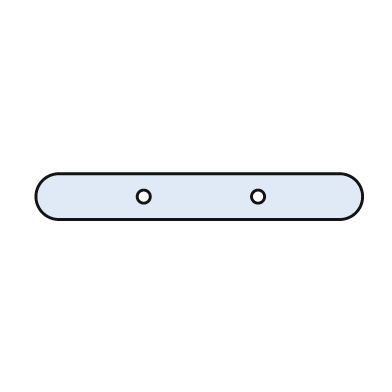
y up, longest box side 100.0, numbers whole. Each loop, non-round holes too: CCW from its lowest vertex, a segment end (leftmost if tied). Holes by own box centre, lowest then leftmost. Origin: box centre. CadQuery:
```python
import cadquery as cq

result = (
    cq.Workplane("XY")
    .moveTo(-43.0, -7.0)
    .lineTo(43.0, -7.0)
    .threePointArc((50.0, 0.0), (43.0, 7.0))
    .lineTo(-43.0, 7.0)
    .threePointArc((-50.0, 0.0), (-43.0, -7.0))
    .close()
    .moveTo(-17.0, 0.0)
    .circle(2.0)
    .moveTo(18.0, 0.0)
    .circle(2.0)
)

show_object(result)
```